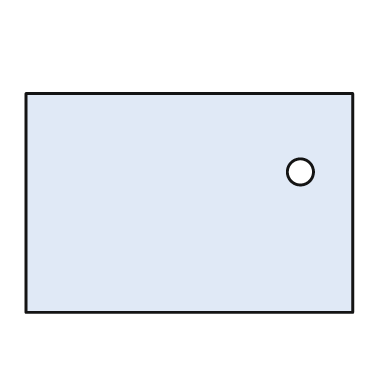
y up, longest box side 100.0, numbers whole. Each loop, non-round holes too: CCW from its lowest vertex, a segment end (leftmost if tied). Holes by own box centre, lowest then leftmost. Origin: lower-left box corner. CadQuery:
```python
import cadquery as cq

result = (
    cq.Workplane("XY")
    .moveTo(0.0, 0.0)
    .lineTo(100.0, 0.0)
    .lineTo(100.0, 67.0)
    .lineTo(0.0, 67.0)
    .close()
    .moveTo(84.0, 43.0)
    .circle(4.0)
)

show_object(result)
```